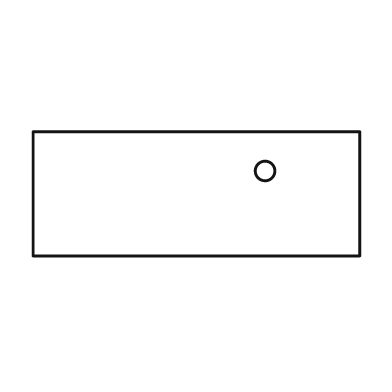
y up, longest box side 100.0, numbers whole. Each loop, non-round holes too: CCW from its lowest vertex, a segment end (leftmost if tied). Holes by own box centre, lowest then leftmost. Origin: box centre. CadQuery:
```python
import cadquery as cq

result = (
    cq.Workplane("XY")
    .moveTo(-50.0, -19.0)
    .lineTo(50.0, -19.0)
    .lineTo(50.0, 19.0)
    .lineTo(-50.0, 19.0)
    .close()
    .moveTo(21.0, 7.0)
    .circle(3.0)
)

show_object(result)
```